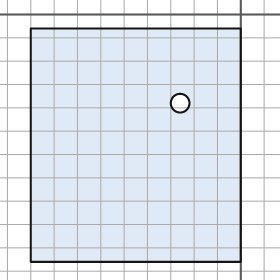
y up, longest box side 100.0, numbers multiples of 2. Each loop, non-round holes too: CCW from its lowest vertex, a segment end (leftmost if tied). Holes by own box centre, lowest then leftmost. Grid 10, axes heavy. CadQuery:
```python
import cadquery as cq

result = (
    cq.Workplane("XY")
    .moveTo(-90.0, -106.0)
    .lineTo(0.0, -106.0)
    .lineTo(0.0, -6.0)
    .lineTo(-90.0, -6.0)
    .close()
    .moveTo(-26.0, -38.0)
    .circle(4.0)
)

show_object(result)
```